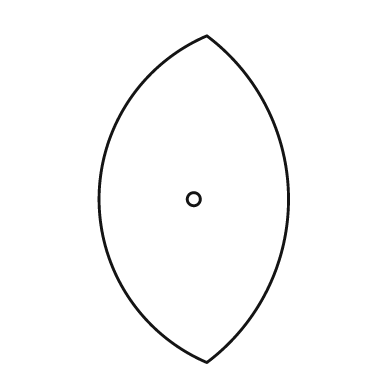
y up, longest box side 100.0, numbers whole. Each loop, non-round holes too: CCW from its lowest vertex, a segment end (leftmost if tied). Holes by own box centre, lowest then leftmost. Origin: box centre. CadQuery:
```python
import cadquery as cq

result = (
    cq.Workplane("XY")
    .moveTo(4.0, -50.0)
    .threePointArc((29.0, 0.0), (4.0, 50.0))
    .threePointArc((-29.0, 0.0), (4.0, -50.0))
    .close()
    .moveTo(0.0, 0.0)
    .circle(2.0)
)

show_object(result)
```